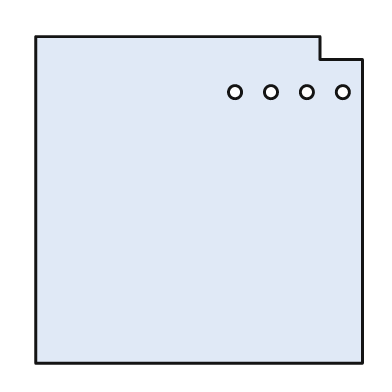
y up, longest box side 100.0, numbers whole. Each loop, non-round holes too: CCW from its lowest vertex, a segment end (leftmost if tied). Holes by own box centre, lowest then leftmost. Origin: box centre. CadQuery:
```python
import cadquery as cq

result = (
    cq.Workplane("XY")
    .moveTo(-50.0, -50.0)
    .lineTo(50.0, -50.0)
    .lineTo(50.0, 43.0)
    .lineTo(37.0, 43.0)
    .lineTo(37.0, 50.0)
    .lineTo(-50.0, 50.0)
    .close()
    .moveTo(11.0, 33.0)
    .circle(2.0)
    .moveTo(22.0, 33.0)
    .circle(2.0)
    .moveTo(33.0, 33.0)
    .circle(2.0)
    .moveTo(44.0, 33.0)
    .circle(2.0)
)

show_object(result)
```